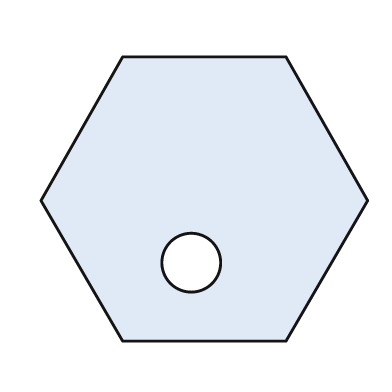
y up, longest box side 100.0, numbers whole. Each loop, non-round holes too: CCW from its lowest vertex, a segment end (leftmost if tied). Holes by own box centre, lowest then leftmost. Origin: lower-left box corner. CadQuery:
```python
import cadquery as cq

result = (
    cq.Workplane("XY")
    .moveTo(25.0, 0.0)
    .lineTo(75.0, 0.0)
    .lineTo(100.0, 43.0)
    .lineTo(75.0, 87.0)
    .lineTo(25.0, 87.0)
    .lineTo(0.0, 43.0)
    .close()
    .moveTo(46.0, 24.0)
    .circle(9.0)
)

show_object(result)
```